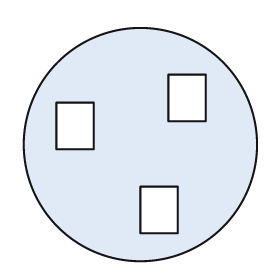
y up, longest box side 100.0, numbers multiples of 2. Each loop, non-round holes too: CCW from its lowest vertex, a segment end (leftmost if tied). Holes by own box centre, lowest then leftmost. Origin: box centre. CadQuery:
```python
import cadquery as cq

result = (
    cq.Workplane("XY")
    .moveTo(0.0, 0.0)
    .circle(50.0)
    .moveTo(0.0, -38.0)
    .lineTo(16.0, -38.0)
    .lineTo(16.0, -18.0)
    .lineTo(0.0, -18.0)
    .close()
    .moveTo(-36.0, -2.0)
    .lineTo(-20.0, -2.0)
    .lineTo(-20.0, 18.0)
    .lineTo(-36.0, 18.0)
    .close()
    .moveTo(12.0, 10.0)
    .lineTo(28.0, 10.0)
    .lineTo(28.0, 30.0)
    .lineTo(12.0, 30.0)
    .close()
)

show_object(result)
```